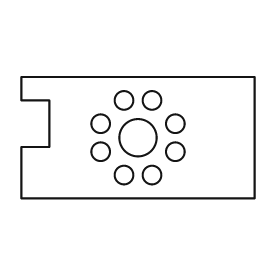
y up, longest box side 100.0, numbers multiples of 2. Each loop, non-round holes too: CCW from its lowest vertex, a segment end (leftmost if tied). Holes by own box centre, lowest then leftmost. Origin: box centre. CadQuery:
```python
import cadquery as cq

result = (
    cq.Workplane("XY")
    .moveTo(-50.0, -26.0)
    .lineTo(50.0, -26.0)
    .lineTo(50.0, 26.0)
    .lineTo(-50.0, 26.0)
    .lineTo(-50.0, 16.0)
    .lineTo(-38.0, 16.0)
    .lineTo(-38.0, -4.0)
    .lineTo(-50.0, -4.0)
    .close()
    .moveTo(-6.0, -16.0)
    .circle(4.0)
    .moveTo(6.0, -16.0)
    .circle(4.0)
    .moveTo(-16.0, -6.0)
    .circle(4.0)
    .moveTo(16.0, -6.0)
    .circle(4.0)
    .moveTo(0.0, 0.0)
    .circle(8.0)
    .moveTo(-16.0, 6.0)
    .circle(4.0)
    .moveTo(16.0, 6.0)
    .circle(4.0)
    .moveTo(-6.0, 16.0)
    .circle(4.0)
    .moveTo(6.0, 16.0)
    .circle(4.0)
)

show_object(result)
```